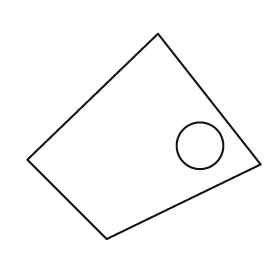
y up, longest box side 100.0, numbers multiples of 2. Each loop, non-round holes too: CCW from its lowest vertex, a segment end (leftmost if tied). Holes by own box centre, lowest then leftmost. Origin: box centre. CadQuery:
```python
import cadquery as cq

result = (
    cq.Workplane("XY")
    .moveTo(-16.0, -44.0)
    .lineTo(50.0, -12.0)
    .lineTo(6.0, 44.0)
    .lineTo(-50.0, -10.0)
    .close()
    .moveTo(24.0, -4.0)
    .circle(10.0)
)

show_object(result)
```